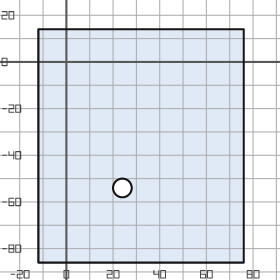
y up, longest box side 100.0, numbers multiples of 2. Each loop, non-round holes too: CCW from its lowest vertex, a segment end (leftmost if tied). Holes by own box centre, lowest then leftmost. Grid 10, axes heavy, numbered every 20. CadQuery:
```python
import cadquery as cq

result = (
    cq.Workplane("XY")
    .moveTo(-12.0, -86.0)
    .lineTo(76.0, -86.0)
    .lineTo(76.0, 14.0)
    .lineTo(-12.0, 14.0)
    .close()
    .moveTo(24.0, -54.0)
    .circle(4.0)
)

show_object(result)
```